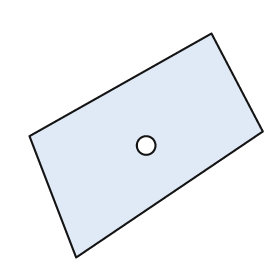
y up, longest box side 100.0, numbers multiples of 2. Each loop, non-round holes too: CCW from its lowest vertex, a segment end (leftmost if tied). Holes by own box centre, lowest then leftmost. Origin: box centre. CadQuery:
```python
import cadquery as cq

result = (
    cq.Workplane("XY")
    .moveTo(-30.0, -48.0)
    .lineTo(50.0, 6.0)
    .lineTo(28.0, 48.0)
    .lineTo(-50.0, 4.0)
    .close()
    .moveTo(0.0, 0.0)
    .circle(4.0)
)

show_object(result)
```